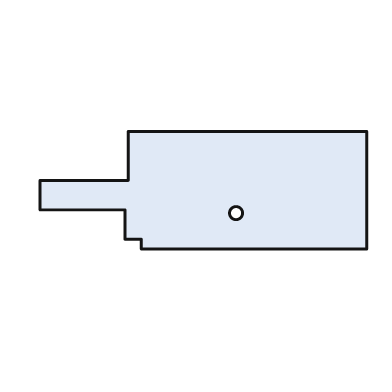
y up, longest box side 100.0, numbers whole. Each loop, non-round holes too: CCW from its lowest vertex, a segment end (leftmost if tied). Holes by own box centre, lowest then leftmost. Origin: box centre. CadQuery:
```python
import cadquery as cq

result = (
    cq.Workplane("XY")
    .moveTo(-19.0, -18.0)
    .lineTo(50.0, -18.0)
    .lineTo(50.0, 18.0)
    .lineTo(-23.0, 18.0)
    .lineTo(-23.0, 3.0)
    .lineTo(-50.0, 3.0)
    .lineTo(-50.0, -6.0)
    .lineTo(-24.0, -6.0)
    .lineTo(-24.0, -15.0)
    .lineTo(-19.0, -15.0)
    .close()
    .moveTo(10.0, -7.0)
    .circle(2.0)
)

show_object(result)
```